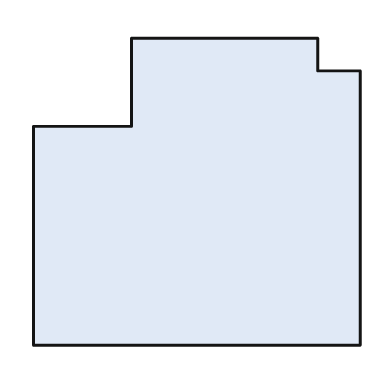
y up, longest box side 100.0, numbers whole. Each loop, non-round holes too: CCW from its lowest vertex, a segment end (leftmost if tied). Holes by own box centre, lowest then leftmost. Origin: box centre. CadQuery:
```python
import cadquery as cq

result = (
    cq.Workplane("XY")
    .moveTo(-50.0, -47.0)
    .lineTo(50.0, -47.0)
    .lineTo(50.0, 37.0)
    .lineTo(37.0, 37.0)
    .lineTo(37.0, 47.0)
    .lineTo(-20.0, 47.0)
    .lineTo(-20.0, 20.0)
    .lineTo(-50.0, 20.0)
    .close()
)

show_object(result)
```